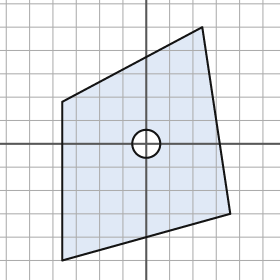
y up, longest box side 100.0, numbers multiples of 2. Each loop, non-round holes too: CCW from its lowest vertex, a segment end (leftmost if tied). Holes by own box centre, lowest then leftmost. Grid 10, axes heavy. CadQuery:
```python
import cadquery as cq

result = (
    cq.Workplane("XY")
    .moveTo(-36.0, -50.0)
    .lineTo(36.0, -30.0)
    .lineTo(24.0, 50.0)
    .lineTo(-36.0, 18.0)
    .close()
    .moveTo(0.0, 0.0)
    .circle(6.0)
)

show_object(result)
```